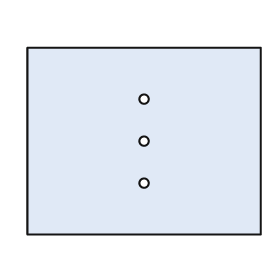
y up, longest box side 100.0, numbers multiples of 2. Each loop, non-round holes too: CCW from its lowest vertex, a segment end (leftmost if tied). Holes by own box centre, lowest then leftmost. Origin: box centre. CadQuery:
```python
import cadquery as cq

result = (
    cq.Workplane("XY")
    .moveTo(-50.0, -40.0)
    .lineTo(50.0, -40.0)
    .lineTo(50.0, 40.0)
    .lineTo(-50.0, 40.0)
    .close()
    .moveTo(0.0, -18.0)
    .circle(2.0)
    .moveTo(0.0, 0.0)
    .circle(2.0)
    .moveTo(0.0, 18.0)
    .circle(2.0)
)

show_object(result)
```